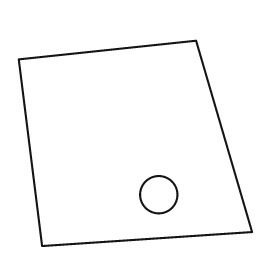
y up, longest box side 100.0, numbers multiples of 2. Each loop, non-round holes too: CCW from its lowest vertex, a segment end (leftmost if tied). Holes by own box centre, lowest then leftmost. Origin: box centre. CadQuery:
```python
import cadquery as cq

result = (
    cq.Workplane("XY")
    .moveTo(-40.0, -44.0)
    .lineTo(50.0, -38.0)
    .lineTo(26.0, 44.0)
    .lineTo(-50.0, 36.0)
    .close()
    .moveTo(10.0, -22.0)
    .circle(8.0)
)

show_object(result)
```